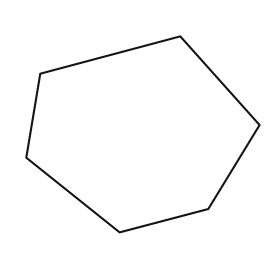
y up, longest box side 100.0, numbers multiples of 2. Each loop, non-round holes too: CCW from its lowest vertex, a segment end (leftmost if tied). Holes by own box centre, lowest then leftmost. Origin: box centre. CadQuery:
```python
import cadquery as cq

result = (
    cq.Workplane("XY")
    .moveTo(-10.0, -42.0)
    .lineTo(28.0, -32.0)
    .lineTo(50.0, 4.0)
    .lineTo(16.0, 42.0)
    .lineTo(-44.0, 26.0)
    .lineTo(-50.0, -10.0)
    .close()
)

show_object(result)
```